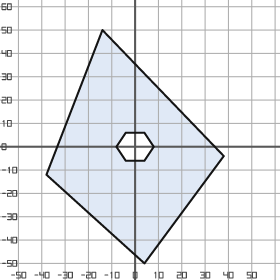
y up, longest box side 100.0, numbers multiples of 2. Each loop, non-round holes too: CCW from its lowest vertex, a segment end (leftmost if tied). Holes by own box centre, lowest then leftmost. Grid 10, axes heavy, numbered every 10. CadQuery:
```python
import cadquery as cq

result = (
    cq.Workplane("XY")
    .moveTo(4.0, -50.0)
    .lineTo(38.0, -4.0)
    .lineTo(-14.0, 50.0)
    .lineTo(-38.0, -12.0)
    .close()
    .moveTo(-4.0, -6.0)
    .lineTo(4.0, -6.0)
    .lineTo(8.0, 0.0)
    .lineTo(4.0, 6.0)
    .lineTo(-4.0, 6.0)
    .lineTo(-8.0, 0.0)
    .close()
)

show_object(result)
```